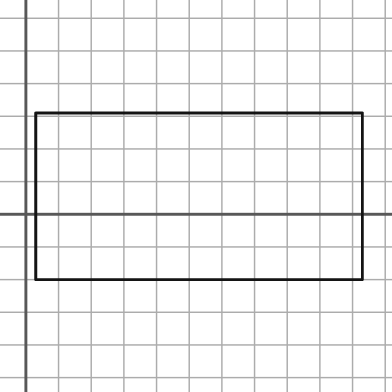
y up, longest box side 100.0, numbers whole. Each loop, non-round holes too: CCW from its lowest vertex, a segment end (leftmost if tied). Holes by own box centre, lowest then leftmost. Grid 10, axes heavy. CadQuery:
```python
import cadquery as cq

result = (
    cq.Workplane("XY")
    .moveTo(3.0, -20.0)
    .lineTo(103.0, -20.0)
    .lineTo(103.0, 31.0)
    .lineTo(3.0, 31.0)
    .close()
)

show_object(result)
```